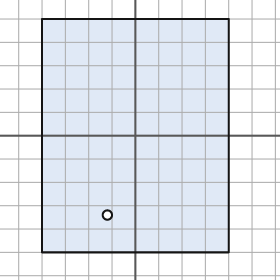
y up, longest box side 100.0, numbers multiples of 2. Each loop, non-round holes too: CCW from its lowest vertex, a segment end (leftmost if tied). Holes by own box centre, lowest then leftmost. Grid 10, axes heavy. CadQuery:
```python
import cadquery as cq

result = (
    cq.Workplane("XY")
    .moveTo(-40.0, -50.0)
    .lineTo(40.0, -50.0)
    .lineTo(40.0, 50.0)
    .lineTo(-40.0, 50.0)
    .close()
    .moveTo(-12.0, -34.0)
    .circle(2.0)
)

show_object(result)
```